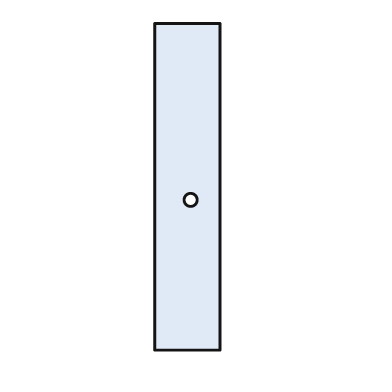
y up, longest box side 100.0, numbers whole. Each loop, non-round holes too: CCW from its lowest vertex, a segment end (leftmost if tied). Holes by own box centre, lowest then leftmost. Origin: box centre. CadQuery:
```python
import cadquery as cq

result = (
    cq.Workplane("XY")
    .moveTo(-10.0, -50.0)
    .lineTo(10.0, -50.0)
    .lineTo(10.0, 50.0)
    .lineTo(-10.0, 50.0)
    .close()
    .moveTo(1.0, -4.0)
    .circle(2.0)
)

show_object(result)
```